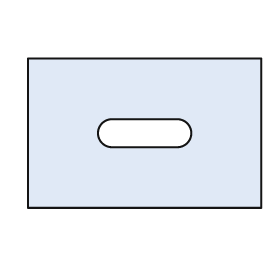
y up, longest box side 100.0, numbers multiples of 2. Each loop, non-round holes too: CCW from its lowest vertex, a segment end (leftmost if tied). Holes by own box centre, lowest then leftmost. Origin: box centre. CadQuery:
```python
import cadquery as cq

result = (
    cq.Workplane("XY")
    .moveTo(-50.0, -32.0)
    .lineTo(50.0, -32.0)
    .lineTo(50.0, 32.0)
    .lineTo(-50.0, 32.0)
    .close()
    .moveTo(-14.0, -6.0)
    .lineTo(14.0, -6.0)
    .threePointArc((20.0, 0.0), (14.0, 6.0))
    .lineTo(-14.0, 6.0)
    .threePointArc((-20.0, 0.0), (-14.0, -6.0))
    .close()
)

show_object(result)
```